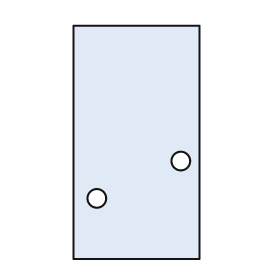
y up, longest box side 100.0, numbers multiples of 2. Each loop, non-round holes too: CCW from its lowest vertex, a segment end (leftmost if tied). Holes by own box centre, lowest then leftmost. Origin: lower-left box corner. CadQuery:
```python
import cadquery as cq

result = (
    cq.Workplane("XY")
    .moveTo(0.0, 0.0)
    .lineTo(54.0, 0.0)
    .lineTo(54.0, 100.0)
    .lineTo(0.0, 100.0)
    .close()
    .moveTo(10.0, 26.0)
    .circle(4.0)
    .moveTo(46.0, 42.0)
    .circle(4.0)
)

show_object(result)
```